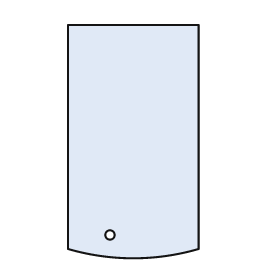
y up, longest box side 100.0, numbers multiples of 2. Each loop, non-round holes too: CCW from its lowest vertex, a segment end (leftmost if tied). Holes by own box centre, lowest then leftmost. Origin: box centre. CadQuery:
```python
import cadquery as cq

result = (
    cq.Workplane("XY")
    .moveTo(-28.0, -46.0)
    .threePointArc((0.0, -50.0), (28.0, -46.0))
    .lineTo(28.0, 50.0)
    .lineTo(-28.0, 50.0)
    .close()
    .moveTo(-10.0, -40.0)
    .circle(2.0)
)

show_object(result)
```